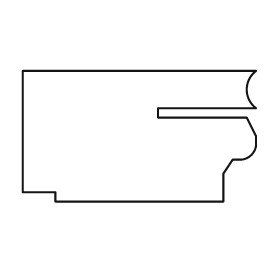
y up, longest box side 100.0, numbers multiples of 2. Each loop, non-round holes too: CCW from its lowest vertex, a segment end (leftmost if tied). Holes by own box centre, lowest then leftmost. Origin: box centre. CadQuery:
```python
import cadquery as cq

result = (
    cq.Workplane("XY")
    .moveTo(-36.0, -28.0)
    .lineTo(36.0, -28.0)
    .lineTo(36.0, -16.0)
    .lineTo(40.0, -10.0)
    .lineTo(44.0, -10.0)
    .threePointArc((48.0, -8.0), (50.0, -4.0))
    .lineTo(50.0, 0.0)
    .lineTo(46.0, 8.0)
    .lineTo(8.0, 8.0)
    .lineTo(8.0, 12.0)
    .lineTo(50.0, 12.0)
    .threePointArc((46.0, 20.0), (50.0, 28.0))
    .lineTo(-50.0, 28.0)
    .lineTo(-50.0, -24.0)
    .lineTo(-36.0, -24.0)
    .close()
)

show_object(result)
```